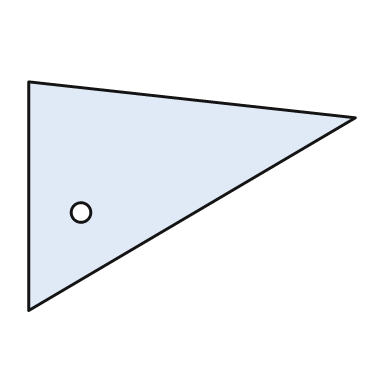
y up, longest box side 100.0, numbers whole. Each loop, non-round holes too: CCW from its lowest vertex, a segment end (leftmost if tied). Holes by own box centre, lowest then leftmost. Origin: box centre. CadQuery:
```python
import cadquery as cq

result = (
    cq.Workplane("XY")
    .moveTo(-50.0, -35.0)
    .lineTo(50.0, 24.0)
    .lineTo(-50.0, 35.0)
    .close()
    .moveTo(-34.0, -5.0)
    .circle(3.0)
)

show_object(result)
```